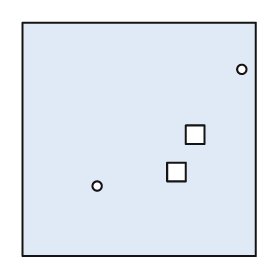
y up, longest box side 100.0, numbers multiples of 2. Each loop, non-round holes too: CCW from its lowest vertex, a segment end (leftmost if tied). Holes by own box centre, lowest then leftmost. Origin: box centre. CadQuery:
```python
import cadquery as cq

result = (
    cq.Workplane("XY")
    .moveTo(-50.0, -50.0)
    .lineTo(50.0, -50.0)
    .lineTo(50.0, 50.0)
    .lineTo(-50.0, 50.0)
    .close()
    .moveTo(-18.0, -20.0)
    .circle(2.0)
    .moveTo(12.0, -18.0)
    .lineTo(20.0, -18.0)
    .lineTo(20.0, -10.0)
    .lineTo(12.0, -10.0)
    .close()
    .moveTo(20.0, -2.0)
    .lineTo(28.0, -2.0)
    .lineTo(28.0, 6.0)
    .lineTo(20.0, 6.0)
    .close()
    .moveTo(44.0, 30.0)
    .circle(2.0)
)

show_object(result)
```